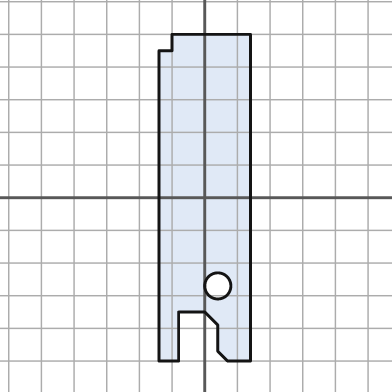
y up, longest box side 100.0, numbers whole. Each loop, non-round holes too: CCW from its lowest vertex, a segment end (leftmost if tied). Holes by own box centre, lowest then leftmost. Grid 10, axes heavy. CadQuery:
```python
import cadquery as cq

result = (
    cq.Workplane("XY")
    .moveTo(-14.0, -50.0)
    .lineTo(-8.0, -50.0)
    .lineTo(-8.0, -35.0)
    .lineTo(0.0, -35.0)
    .lineTo(4.0, -39.0)
    .lineTo(4.0, -47.0)
    .lineTo(7.0, -50.0)
    .lineTo(14.0, -50.0)
    .lineTo(14.0, 50.0)
    .lineTo(-10.0, 50.0)
    .lineTo(-10.0, 45.0)
    .lineTo(-14.0, 45.0)
    .close()
    .moveTo(4.0, -27.0)
    .circle(4.0)
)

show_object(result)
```